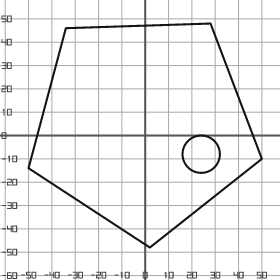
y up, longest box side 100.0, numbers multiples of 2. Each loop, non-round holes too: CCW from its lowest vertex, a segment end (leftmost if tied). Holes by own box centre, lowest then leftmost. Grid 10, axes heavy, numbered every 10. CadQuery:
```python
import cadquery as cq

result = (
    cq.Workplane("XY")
    .moveTo(2.0, -48.0)
    .lineTo(50.0, -10.0)
    .lineTo(28.0, 48.0)
    .lineTo(-34.0, 46.0)
    .lineTo(-50.0, -14.0)
    .close()
    .moveTo(24.0, -8.0)
    .circle(8.0)
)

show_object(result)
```